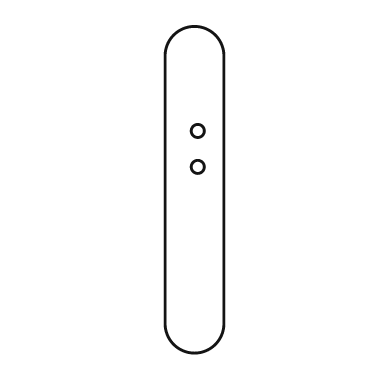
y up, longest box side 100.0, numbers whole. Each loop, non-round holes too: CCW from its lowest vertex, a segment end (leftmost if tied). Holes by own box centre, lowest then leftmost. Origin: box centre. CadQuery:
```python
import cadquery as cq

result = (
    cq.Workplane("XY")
    .moveTo(-9.0, -41.0)
    .threePointArc((0.0, -50.0), (9.0, -41.0))
    .lineTo(9.0, 41.0)
    .threePointArc((0.0, 50.0), (-9.0, 41.0))
    .close()
    .moveTo(1.0, 7.0)
    .circle(2.0)
    .moveTo(1.0, 18.0)
    .circle(2.0)
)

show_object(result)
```